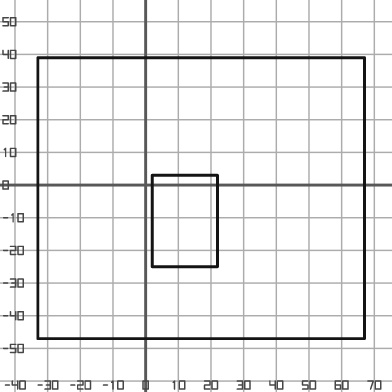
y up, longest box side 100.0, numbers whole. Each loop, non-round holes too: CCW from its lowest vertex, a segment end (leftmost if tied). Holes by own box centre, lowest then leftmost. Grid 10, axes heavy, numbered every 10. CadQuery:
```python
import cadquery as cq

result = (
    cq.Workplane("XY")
    .moveTo(-33.0, -47.0)
    .lineTo(67.0, -47.0)
    .lineTo(67.0, 39.0)
    .lineTo(-33.0, 39.0)
    .close()
    .moveTo(2.0, -25.0)
    .lineTo(22.0, -25.0)
    .lineTo(22.0, 3.0)
    .lineTo(2.0, 3.0)
    .close()
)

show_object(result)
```